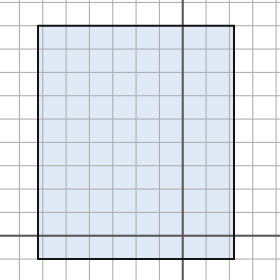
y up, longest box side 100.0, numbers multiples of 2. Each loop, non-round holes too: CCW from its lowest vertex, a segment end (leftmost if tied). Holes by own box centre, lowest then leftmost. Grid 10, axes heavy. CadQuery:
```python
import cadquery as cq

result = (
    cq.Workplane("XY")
    .moveTo(-62.0, -10.0)
    .lineTo(22.0, -10.0)
    .lineTo(22.0, 90.0)
    .lineTo(-62.0, 90.0)
    .close()
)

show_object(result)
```